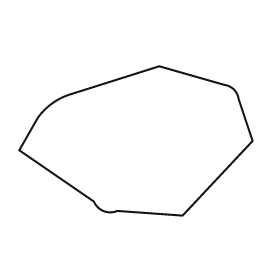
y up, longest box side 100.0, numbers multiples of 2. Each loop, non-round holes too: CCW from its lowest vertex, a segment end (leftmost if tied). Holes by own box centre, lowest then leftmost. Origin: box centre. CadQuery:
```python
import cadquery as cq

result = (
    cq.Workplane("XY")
    .moveTo(20.0, -32.0)
    .lineTo(50.0, 0.0)
    .lineTo(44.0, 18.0)
    .threePointArc((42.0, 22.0), (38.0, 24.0))
    .lineTo(10.0, 32.0)
    .lineTo(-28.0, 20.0)
    .threePointArc((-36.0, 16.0), (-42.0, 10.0))
    .lineTo(-50.0, -4.0)
    .lineTo(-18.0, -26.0)
    .threePointArc((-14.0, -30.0), (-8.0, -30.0))
    .close()
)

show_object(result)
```